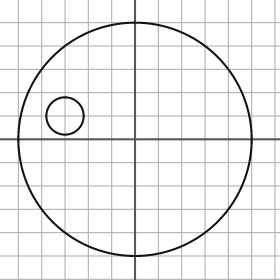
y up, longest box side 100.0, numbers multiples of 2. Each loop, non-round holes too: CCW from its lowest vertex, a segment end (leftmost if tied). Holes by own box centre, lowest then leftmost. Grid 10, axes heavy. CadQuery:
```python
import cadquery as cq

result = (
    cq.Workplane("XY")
    .moveTo(0.0, 0.0)
    .circle(50.0)
    .moveTo(-30.0, 10.0)
    .circle(8.0)
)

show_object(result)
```